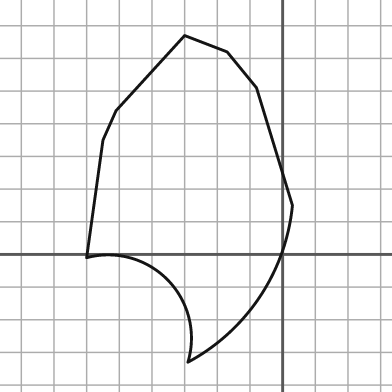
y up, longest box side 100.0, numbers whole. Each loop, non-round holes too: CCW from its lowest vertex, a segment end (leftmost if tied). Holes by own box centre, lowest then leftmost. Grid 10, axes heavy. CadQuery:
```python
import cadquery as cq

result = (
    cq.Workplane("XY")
    .moveTo(-29.0, -33.0)
    .threePointArc((-7.0, -13.0), (3.0, 15.0))
    .lineTo(-8.0, 51.0)
    .lineTo(-17.0, 62.0)
    .lineTo(-30.0, 67.0)
    .lineTo(-51.0, 44.0)
    .lineTo(-55.0, 35.0)
    .lineTo(-60.0, -1.0)
    .threePointArc((-35.0, -8.0), (-29.0, -33.0))
    .close()
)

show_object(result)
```